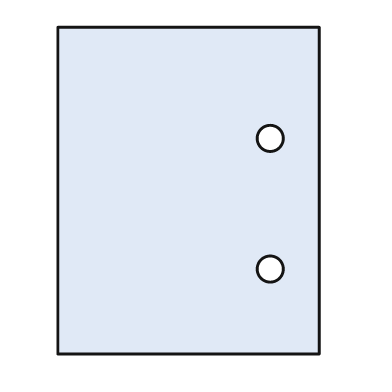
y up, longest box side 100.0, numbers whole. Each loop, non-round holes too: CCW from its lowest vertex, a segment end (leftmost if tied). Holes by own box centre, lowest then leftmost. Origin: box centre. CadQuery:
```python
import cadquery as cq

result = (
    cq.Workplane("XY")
    .moveTo(-40.0, -50.0)
    .lineTo(40.0, -50.0)
    .lineTo(40.0, 50.0)
    .lineTo(-40.0, 50.0)
    .close()
    .moveTo(25.0, -24.0)
    .circle(4.0)
    .moveTo(25.0, 16.0)
    .circle(4.0)
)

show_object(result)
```